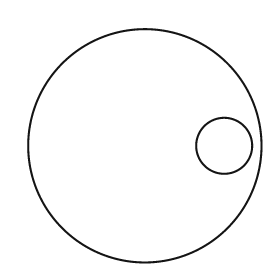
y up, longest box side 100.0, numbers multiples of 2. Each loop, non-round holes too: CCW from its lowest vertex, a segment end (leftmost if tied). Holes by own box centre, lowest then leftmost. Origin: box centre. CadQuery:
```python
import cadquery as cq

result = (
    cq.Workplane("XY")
    .moveTo(0.0, 0.0)
    .circle(50.0)
    .moveTo(34.0, 0.0)
    .circle(12.0)
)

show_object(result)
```